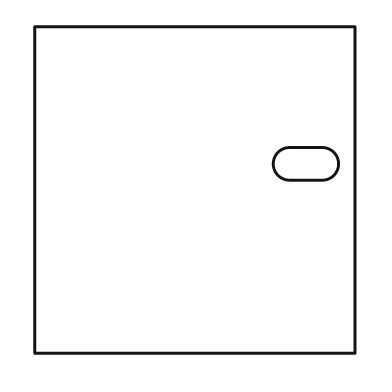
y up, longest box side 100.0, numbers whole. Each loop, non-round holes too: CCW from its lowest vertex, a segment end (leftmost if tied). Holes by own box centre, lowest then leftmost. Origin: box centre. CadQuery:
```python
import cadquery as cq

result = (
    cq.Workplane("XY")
    .moveTo(-49.0, -50.0)
    .lineTo(49.0, -50.0)
    .lineTo(49.0, 50.0)
    .lineTo(-49.0, 50.0)
    .close()
    .moveTo(29.0, 3.0)
    .lineTo(39.0, 3.0)
    .threePointArc((44.0, 8.0), (39.0, 13.0))
    .lineTo(29.0, 13.0)
    .threePointArc((24.0, 8.0), (29.0, 3.0))
    .close()
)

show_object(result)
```